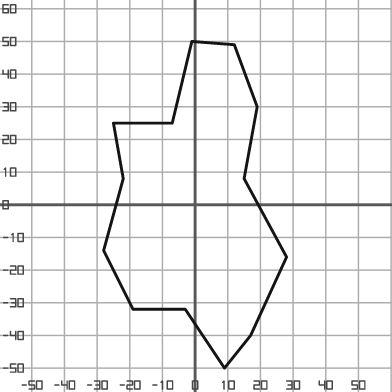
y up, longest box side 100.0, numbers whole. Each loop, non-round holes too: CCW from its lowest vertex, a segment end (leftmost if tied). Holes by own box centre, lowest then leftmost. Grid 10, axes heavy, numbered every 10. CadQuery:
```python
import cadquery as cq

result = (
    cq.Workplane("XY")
    .moveTo(9.0, -50.0)
    .lineTo(17.0, -40.0)
    .lineTo(28.0, -16.0)
    .lineTo(15.0, 8.0)
    .lineTo(19.0, 30.0)
    .lineTo(12.0, 49.0)
    .lineTo(-1.0, 50.0)
    .lineTo(-7.0, 25.0)
    .lineTo(-25.0, 25.0)
    .lineTo(-22.0, 8.0)
    .lineTo(-28.0, -14.0)
    .lineTo(-19.0, -32.0)
    .lineTo(-3.0, -32.0)
    .close()
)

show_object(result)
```